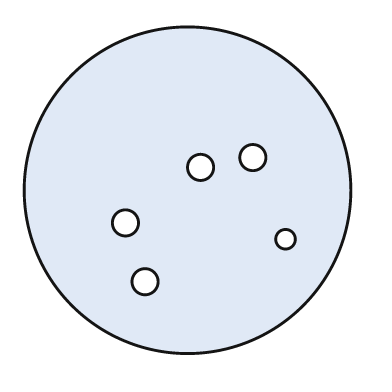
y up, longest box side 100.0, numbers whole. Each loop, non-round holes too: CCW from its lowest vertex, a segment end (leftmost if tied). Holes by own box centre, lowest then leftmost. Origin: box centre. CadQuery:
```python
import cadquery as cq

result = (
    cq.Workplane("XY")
    .moveTo(0.0, 0.0)
    .circle(50.0)
    .moveTo(-13.0, -28.0)
    .circle(4.0)
    .moveTo(30.0, -15.0)
    .circle(3.0)
    .moveTo(-19.0, -10.0)
    .circle(4.0)
    .moveTo(4.0, 7.0)
    .circle(4.0)
    .moveTo(20.0, 10.0)
    .circle(4.0)
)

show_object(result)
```